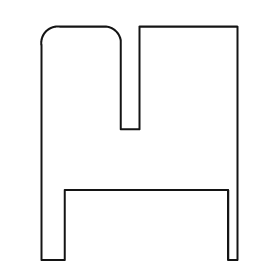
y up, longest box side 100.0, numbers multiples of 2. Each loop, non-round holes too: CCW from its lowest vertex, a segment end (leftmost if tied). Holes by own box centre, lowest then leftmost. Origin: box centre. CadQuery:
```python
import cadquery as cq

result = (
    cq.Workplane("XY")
    .moveTo(-42.0, -50.0)
    .lineTo(-32.0, -50.0)
    .lineTo(-32.0, -20.0)
    .lineTo(38.0, -20.0)
    .lineTo(38.0, -50.0)
    .lineTo(42.0, -50.0)
    .lineTo(42.0, 50.0)
    .lineTo(0.0, 50.0)
    .lineTo(0.0, 6.0)
    .lineTo(-8.0, 6.0)
    .lineTo(-8.0, 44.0)
    .threePointArc((-10.0, 48.0), (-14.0, 50.0))
    .lineTo(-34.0, 50.0)
    .threePointArc((-40.0, 48.0), (-42.0, 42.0))
    .close()
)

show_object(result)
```